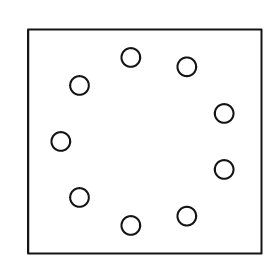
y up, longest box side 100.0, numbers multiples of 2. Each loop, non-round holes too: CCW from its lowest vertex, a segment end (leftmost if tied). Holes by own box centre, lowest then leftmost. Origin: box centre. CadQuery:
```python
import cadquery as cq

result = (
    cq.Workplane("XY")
    .moveTo(-50.0, -48.0)
    .lineTo(50.0, -48.0)
    .lineTo(50.0, 48.0)
    .lineTo(-50.0, 48.0)
    .close()
    .moveTo(-6.0, -36.0)
    .circle(4.0)
    .moveTo(18.0, -32.0)
    .circle(4.0)
    .moveTo(-28.0, -24.0)
    .circle(4.0)
    .moveTo(34.0, -12.0)
    .circle(4.0)
    .moveTo(-36.0, 0.0)
    .circle(4.0)
    .moveTo(34.0, 12.0)
    .circle(4.0)
    .moveTo(-28.0, 24.0)
    .circle(4.0)
    .moveTo(18.0, 32.0)
    .circle(4.0)
    .moveTo(-6.0, 36.0)
    .circle(4.0)
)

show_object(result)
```